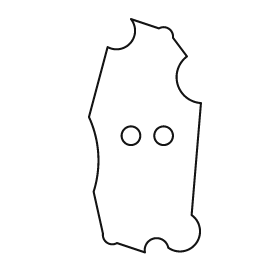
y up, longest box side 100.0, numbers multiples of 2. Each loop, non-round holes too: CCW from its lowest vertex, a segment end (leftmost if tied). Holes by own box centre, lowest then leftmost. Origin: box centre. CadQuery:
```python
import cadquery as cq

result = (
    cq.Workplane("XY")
    .moveTo(0.0, -50.0)
    .threePointArc((4.0, -44.0), (10.0, -48.0))
    .threePointArc((22.0, -46.0), (20.0, -34.0))
    .lineTo(24.0, 14.0)
    .threePointArc((14.0, 22.0), (18.0, 34.0))
    .lineTo(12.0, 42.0)
    .threePointArc((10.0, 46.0), (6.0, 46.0))
    .lineTo(-6.0, 50.0)
    .threePointArc((-6.0, 40.0), (-16.0, 38.0))
    .lineTo(-24.0, 8.0)
    .threePointArc((-20.0, -8.0), (-22.0, -24.0))
    .lineTo(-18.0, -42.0)
    .threePointArc((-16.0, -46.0), (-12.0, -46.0))
    .close()
    .moveTo(-6.0, 0.0)
    .circle(4.0)
    .moveTo(8.0, 0.0)
    .circle(4.0)
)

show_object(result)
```